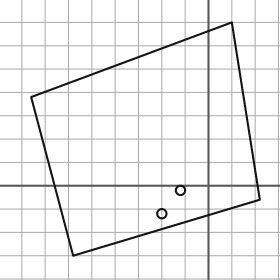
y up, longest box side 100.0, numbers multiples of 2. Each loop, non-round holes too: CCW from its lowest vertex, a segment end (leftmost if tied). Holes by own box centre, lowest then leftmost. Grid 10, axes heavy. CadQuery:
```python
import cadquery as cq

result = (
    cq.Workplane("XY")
    .moveTo(-58.0, -30.0)
    .lineTo(22.0, -6.0)
    .lineTo(10.0, 70.0)
    .lineTo(-76.0, 38.0)
    .close()
    .moveTo(-20.0, -12.0)
    .circle(2.0)
    .moveTo(-12.0, -2.0)
    .circle(2.0)
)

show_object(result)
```